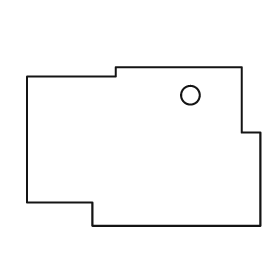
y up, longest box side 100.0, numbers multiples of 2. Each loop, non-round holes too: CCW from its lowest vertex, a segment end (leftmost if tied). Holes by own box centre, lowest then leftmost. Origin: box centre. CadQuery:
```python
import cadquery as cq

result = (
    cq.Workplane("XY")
    .moveTo(-22.0, -34.0)
    .lineTo(50.0, -34.0)
    .lineTo(50.0, 6.0)
    .lineTo(42.0, 6.0)
    .lineTo(42.0, 34.0)
    .lineTo(-12.0, 34.0)
    .lineTo(-12.0, 30.0)
    .lineTo(-50.0, 30.0)
    .lineTo(-50.0, -24.0)
    .lineTo(-22.0, -24.0)
    .close()
    .moveTo(20.0, 22.0)
    .circle(4.0)
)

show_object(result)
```